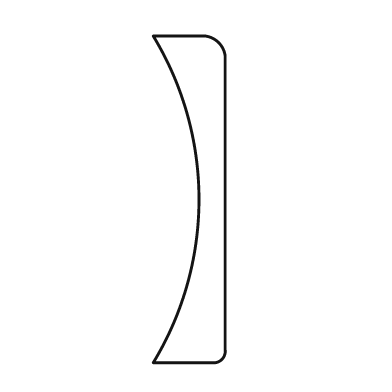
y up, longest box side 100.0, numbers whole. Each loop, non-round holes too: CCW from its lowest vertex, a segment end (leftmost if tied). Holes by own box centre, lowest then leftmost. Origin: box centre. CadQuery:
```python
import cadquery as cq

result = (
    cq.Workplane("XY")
    .moveTo(-11.0, -50.0)
    .lineTo(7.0, -50.0)
    .threePointArc((10.0, -49.0), (11.0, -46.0))
    .lineTo(11.0, 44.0)
    .threePointArc((9.0, 48.0), (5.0, 50.0))
    .lineTo(-11.0, 50.0)
    .threePointArc((3.0, 0.0), (-11.0, -50.0))
    .close()
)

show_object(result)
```